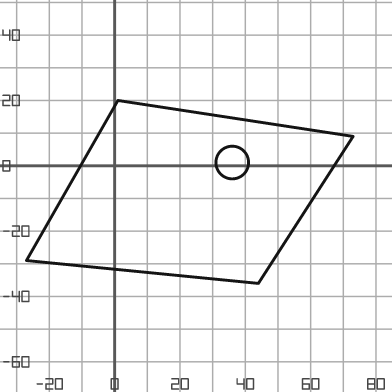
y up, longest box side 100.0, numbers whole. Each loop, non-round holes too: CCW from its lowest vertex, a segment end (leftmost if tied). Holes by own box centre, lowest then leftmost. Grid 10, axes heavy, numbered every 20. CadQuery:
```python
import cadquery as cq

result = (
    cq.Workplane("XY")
    .moveTo(44.0, -36.0)
    .lineTo(73.0, 9.0)
    .lineTo(1.0, 20.0)
    .lineTo(-27.0, -29.0)
    .close()
    .moveTo(36.0, 1.0)
    .circle(5.0)
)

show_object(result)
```